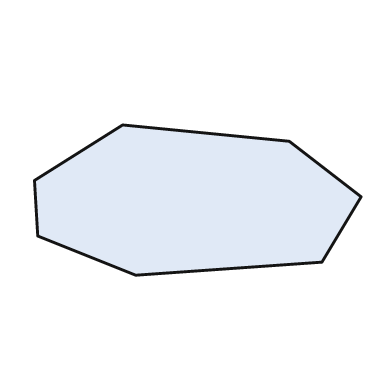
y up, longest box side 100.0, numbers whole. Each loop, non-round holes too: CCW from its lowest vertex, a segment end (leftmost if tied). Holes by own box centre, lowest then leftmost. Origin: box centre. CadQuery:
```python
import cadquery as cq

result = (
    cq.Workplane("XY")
    .moveTo(-19.0, -23.0)
    .lineTo(38.0, -19.0)
    .lineTo(50.0, 1.0)
    .lineTo(28.0, 18.0)
    .lineTo(-23.0, 23.0)
    .lineTo(-50.0, 6.0)
    .lineTo(-49.0, -11.0)
    .close()
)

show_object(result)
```